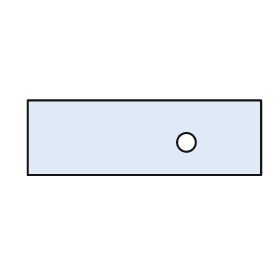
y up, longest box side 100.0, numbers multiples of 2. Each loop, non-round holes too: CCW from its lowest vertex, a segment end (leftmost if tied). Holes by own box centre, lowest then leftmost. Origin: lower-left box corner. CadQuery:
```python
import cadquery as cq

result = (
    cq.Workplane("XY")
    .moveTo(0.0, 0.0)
    .lineTo(100.0, 0.0)
    .lineTo(100.0, 32.0)
    .lineTo(0.0, 32.0)
    .close()
    .moveTo(68.0, 14.0)
    .circle(4.0)
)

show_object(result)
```